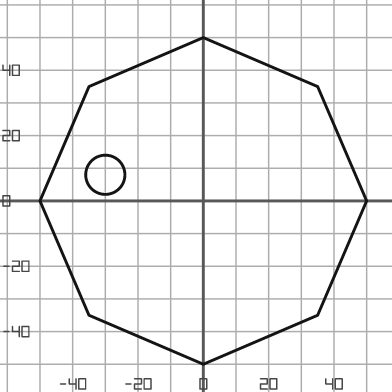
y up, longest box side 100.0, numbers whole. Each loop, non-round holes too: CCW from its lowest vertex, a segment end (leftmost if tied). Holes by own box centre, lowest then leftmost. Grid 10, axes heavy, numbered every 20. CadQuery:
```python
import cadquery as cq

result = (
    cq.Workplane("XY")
    .moveTo(0.0, -50.0)
    .lineTo(35.0, -35.0)
    .lineTo(50.0, 0.0)
    .lineTo(35.0, 35.0)
    .lineTo(0.0, 50.0)
    .lineTo(-35.0, 35.0)
    .lineTo(-50.0, 0.0)
    .lineTo(-35.0, -35.0)
    .close()
    .moveTo(-30.0, 8.0)
    .circle(6.0)
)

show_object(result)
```